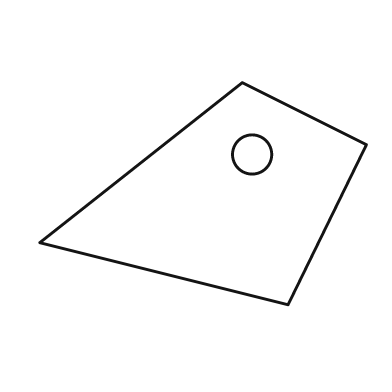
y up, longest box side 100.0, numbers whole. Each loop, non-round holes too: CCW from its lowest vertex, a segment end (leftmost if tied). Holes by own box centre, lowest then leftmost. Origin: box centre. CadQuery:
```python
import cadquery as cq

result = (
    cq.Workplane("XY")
    .moveTo(26.0, -34.0)
    .lineTo(50.0, 15.0)
    .lineTo(12.0, 34.0)
    .lineTo(-50.0, -15.0)
    .close()
    .moveTo(15.0, 12.0)
    .circle(6.0)
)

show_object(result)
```